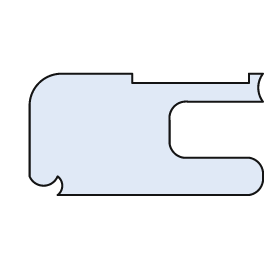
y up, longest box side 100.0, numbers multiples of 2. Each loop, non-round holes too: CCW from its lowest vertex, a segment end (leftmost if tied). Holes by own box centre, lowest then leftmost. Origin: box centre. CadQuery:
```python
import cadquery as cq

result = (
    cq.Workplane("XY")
    .moveTo(-38.0, -26.0)
    .lineTo(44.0, -26.0)
    .threePointArc((48.0, -24.0), (50.0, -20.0))
    .lineTo(50.0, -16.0)
    .threePointArc((48.0, -12.0), (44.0, -10.0))
    .lineTo(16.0, -10.0)
    .threePointArc((12.0, -8.0), (10.0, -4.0))
    .lineTo(10.0, 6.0)
    .threePointArc((12.0, 12.0), (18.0, 14.0))
    .lineTo(50.0, 14.0)
    .threePointArc((48.0, 20.0), (50.0, 26.0))
    .lineTo(44.0, 26.0)
    .lineTo(44.0, 22.0)
    .lineTo(-6.0, 22.0)
    .lineTo(-6.0, 26.0)
    .lineTo(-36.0, 26.0)
    .threePointArc((-46.0, 22.0), (-50.0, 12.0))
    .lineTo(-50.0, -18.0)
    .threePointArc((-44.0, -22.0), (-38.0, -18.0))
    .threePointArc((-36.0, -22.0), (-38.0, -26.0))
    .close()
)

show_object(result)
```